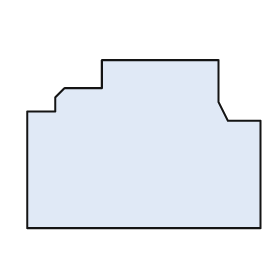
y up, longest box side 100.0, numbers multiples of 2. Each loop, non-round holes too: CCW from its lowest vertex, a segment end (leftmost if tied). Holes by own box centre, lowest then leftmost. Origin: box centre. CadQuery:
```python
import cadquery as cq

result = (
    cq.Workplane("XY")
    .moveTo(-50.0, -36.0)
    .lineTo(50.0, -36.0)
    .lineTo(50.0, 10.0)
    .lineTo(36.0, 10.0)
    .lineTo(32.0, 18.0)
    .lineTo(32.0, 36.0)
    .lineTo(-18.0, 36.0)
    .lineTo(-18.0, 24.0)
    .lineTo(-34.0, 24.0)
    .lineTo(-38.0, 20.0)
    .lineTo(-38.0, 14.0)
    .lineTo(-50.0, 14.0)
    .close()
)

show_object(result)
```